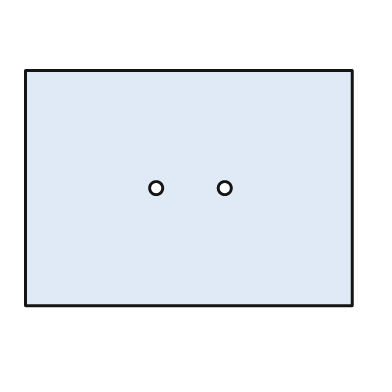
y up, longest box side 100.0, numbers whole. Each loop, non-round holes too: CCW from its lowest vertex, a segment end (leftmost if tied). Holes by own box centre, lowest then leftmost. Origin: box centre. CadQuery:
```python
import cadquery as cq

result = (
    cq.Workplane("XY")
    .moveTo(-50.0, -36.0)
    .lineTo(50.0, -36.0)
    .lineTo(50.0, 36.0)
    .lineTo(-50.0, 36.0)
    .close()
    .moveTo(-10.0, 0.0)
    .circle(2.0)
    .moveTo(11.0, 0.0)
    .circle(2.0)
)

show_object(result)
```